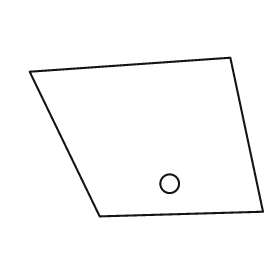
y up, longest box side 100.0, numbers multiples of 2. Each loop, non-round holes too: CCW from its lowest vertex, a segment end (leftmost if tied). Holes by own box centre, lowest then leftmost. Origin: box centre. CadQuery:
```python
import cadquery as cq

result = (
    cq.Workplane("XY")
    .moveTo(-20.0, -34.0)
    .lineTo(50.0, -32.0)
    .lineTo(36.0, 34.0)
    .lineTo(-50.0, 28.0)
    .close()
    .moveTo(10.0, -20.0)
    .circle(4.0)
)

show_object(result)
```